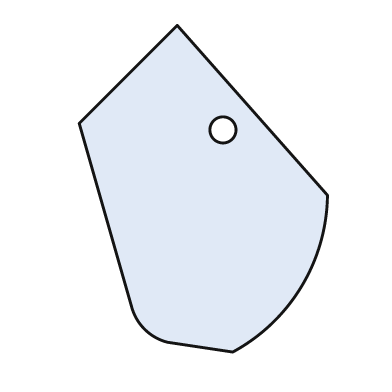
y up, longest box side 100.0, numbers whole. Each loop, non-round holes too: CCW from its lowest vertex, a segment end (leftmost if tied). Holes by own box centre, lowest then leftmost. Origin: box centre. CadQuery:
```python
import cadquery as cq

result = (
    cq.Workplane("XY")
    .moveTo(9.0, -50.0)
    .threePointArc((30.0, -30.0), (38.0, -2.0))
    .lineTo(-8.0, 50.0)
    .lineTo(-38.0, 20.0)
    .lineTo(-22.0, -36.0)
    .threePointArc((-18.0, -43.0), (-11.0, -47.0))
    .close()
    .moveTo(6.0, 18.0)
    .circle(4.0)
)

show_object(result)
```